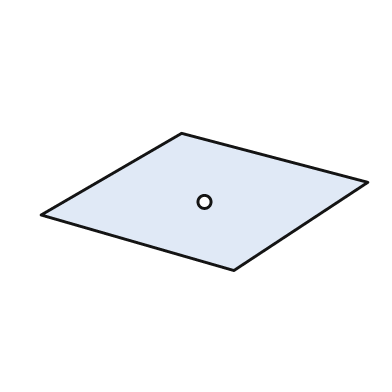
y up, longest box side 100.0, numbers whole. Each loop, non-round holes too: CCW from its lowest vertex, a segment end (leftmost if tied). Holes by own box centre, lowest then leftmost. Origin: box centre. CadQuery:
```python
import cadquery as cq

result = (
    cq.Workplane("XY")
    .moveTo(9.0, -21.0)
    .lineTo(50.0, 6.0)
    .lineTo(-7.0, 21.0)
    .lineTo(-50.0, -4.0)
    .close()
    .moveTo(0.0, 0.0)
    .circle(2.0)
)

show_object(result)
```